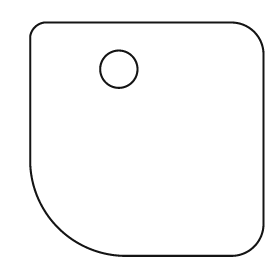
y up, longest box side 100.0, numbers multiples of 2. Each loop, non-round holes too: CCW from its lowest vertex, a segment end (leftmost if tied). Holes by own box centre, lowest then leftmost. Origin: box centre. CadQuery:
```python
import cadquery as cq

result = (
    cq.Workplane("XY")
    .moveTo(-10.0, -50.0)
    .lineTo(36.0, -50.0)
    .threePointArc((46.0, -46.0), (50.0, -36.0))
    .lineTo(50.0, 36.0)
    .threePointArc((46.0, 46.0), (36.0, 50.0))
    .lineTo(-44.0, 50.0)
    .threePointArc((-48.0, 48.0), (-50.0, 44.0))
    .lineTo(-50.0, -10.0)
    .threePointArc((-38.0, -38.0), (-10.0, -50.0))
    .close()
    .moveTo(-12.0, 30.0)
    .circle(8.0)
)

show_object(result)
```